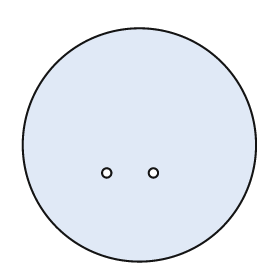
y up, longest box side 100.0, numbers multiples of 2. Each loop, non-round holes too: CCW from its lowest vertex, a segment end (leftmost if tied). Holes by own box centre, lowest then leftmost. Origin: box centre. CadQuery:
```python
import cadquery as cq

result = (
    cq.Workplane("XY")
    .moveTo(0.0, 0.0)
    .circle(50.0)
    .moveTo(-14.0, -12.0)
    .circle(2.0)
    .moveTo(6.0, -12.0)
    .circle(2.0)
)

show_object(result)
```